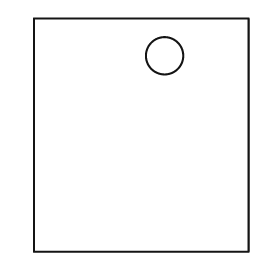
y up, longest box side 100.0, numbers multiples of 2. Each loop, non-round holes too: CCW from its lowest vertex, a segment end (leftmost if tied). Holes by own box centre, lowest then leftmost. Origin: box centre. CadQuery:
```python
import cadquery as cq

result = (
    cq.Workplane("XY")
    .moveTo(-46.0, -50.0)
    .lineTo(46.0, -50.0)
    .lineTo(46.0, 50.0)
    .lineTo(-46.0, 50.0)
    .close()
    .moveTo(10.0, 34.0)
    .circle(8.0)
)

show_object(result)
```